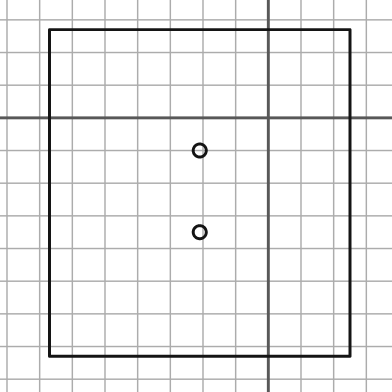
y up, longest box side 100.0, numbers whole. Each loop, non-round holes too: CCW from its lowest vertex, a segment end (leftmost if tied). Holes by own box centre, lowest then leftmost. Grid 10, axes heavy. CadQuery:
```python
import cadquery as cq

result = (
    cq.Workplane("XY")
    .moveTo(-67.0, -73.0)
    .lineTo(25.0, -73.0)
    .lineTo(25.0, 27.0)
    .lineTo(-67.0, 27.0)
    .close()
    .moveTo(-21.0, -35.0)
    .circle(2.0)
    .moveTo(-21.0, -10.0)
    .circle(2.0)
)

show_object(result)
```